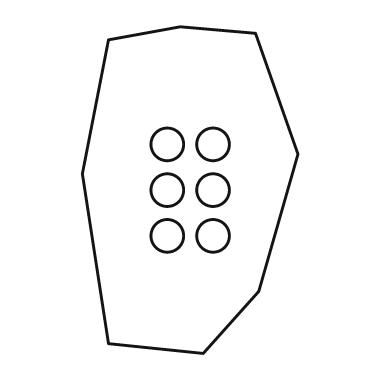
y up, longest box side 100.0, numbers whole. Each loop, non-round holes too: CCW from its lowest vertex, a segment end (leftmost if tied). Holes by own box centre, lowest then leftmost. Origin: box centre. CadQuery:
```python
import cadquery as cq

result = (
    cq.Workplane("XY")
    .moveTo(4.0, -50.0)
    .lineTo(21.0, -31.0)
    .lineTo(33.0, 11.0)
    .lineTo(20.0, 48.0)
    .lineTo(-3.0, 50.0)
    .lineTo(-25.0, 46.0)
    .lineTo(-33.0, 5.0)
    .lineTo(-25.0, -47.0)
    .close()
    .moveTo(-7.0, -14.0)
    .circle(5.0)
    .moveTo(7.0, -14.0)
    .circle(5.0)
    .moveTo(-7.0, 0.0)
    .circle(5.0)
    .moveTo(7.0, 0.0)
    .circle(5.0)
    .moveTo(-7.0, 14.0)
    .circle(5.0)
    .moveTo(7.0, 14.0)
    .circle(5.0)
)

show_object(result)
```